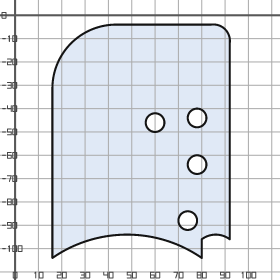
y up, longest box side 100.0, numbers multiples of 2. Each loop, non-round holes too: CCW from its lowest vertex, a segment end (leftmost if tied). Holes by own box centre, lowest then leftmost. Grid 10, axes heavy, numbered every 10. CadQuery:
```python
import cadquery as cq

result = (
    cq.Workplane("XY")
    .moveTo(16.0, -104.0)
    .threePointArc((48.0, -94.0), (80.0, -104.0))
    .lineTo(80.0, -96.0)
    .threePointArc((86.0, -94.0), (92.0, -96.0))
    .lineTo(92.0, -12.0)
    .threePointArc((90.0, -6.0), (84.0, -4.0))
    .lineTo(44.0, -4.0)
    .threePointArc((24.0, -12.0), (16.0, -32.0))
    .close()
    .moveTo(74.0, -88.0)
    .circle(4.0)
    .moveTo(78.0, -64.0)
    .circle(4.0)
    .moveTo(60.0, -46.0)
    .circle(4.0)
    .moveTo(78.0, -44.0)
    .circle(4.0)
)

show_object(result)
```